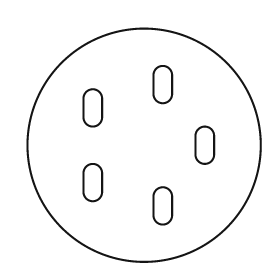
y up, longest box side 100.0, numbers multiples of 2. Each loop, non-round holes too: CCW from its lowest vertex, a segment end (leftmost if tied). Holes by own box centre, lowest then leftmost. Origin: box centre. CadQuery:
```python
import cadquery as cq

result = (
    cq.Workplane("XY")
    .moveTo(0.0, 0.0)
    .circle(50.0)
    .moveTo(4.0, -30.0)
    .threePointArc((8.0, -34.0), (12.0, -30.0))
    .lineTo(12.0, -22.0)
    .threePointArc((8.0, -18.0), (4.0, -22.0))
    .close()
    .moveTo(-26.0, -20.0)
    .threePointArc((-22.0, -24.0), (-18.0, -20.0))
    .lineTo(-18.0, -12.0)
    .threePointArc((-22.0, -8.0), (-26.0, -12.0))
    .close()
    .moveTo(22.0, -4.0)
    .threePointArc((26.0, -8.0), (30.0, -4.0))
    .lineTo(30.0, 4.0)
    .threePointArc((26.0, 8.0), (22.0, 4.0))
    .close()
    .moveTo(-26.0, 12.0)
    .threePointArc((-22.0, 8.0), (-18.0, 12.0))
    .lineTo(-18.0, 20.0)
    .threePointArc((-22.0, 24.0), (-26.0, 20.0))
    .close()
    .moveTo(4.0, 22.0)
    .threePointArc((8.0, 18.0), (12.0, 22.0))
    .lineTo(12.0, 30.0)
    .threePointArc((8.0, 34.0), (4.0, 30.0))
    .close()
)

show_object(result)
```